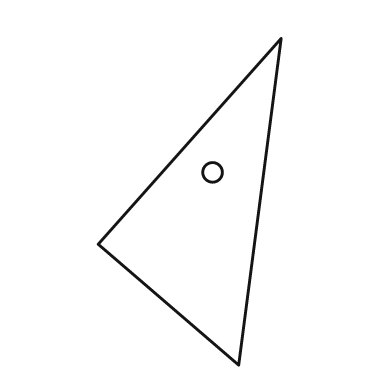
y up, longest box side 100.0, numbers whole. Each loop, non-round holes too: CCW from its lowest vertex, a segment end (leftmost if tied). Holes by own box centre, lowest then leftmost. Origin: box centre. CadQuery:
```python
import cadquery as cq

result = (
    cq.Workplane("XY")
    .moveTo(15.0, -50.0)
    .lineTo(28.0, 50.0)
    .lineTo(-28.0, -13.0)
    .close()
    .moveTo(7.0, 9.0)
    .circle(3.0)
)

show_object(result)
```